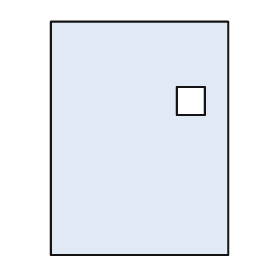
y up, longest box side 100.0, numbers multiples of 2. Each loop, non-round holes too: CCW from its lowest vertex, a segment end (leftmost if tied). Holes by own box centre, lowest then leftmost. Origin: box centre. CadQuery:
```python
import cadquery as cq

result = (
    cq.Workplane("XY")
    .moveTo(-38.0, -50.0)
    .lineTo(38.0, -50.0)
    .lineTo(38.0, 50.0)
    .lineTo(-38.0, 50.0)
    .close()
    .moveTo(16.0, 10.0)
    .lineTo(28.0, 10.0)
    .lineTo(28.0, 22.0)
    .lineTo(16.0, 22.0)
    .close()
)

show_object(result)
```